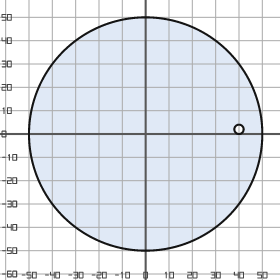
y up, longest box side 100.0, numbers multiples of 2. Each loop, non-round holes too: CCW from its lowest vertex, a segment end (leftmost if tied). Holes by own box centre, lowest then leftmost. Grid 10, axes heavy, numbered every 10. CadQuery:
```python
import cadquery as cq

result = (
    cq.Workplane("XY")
    .moveTo(0.0, 0.0)
    .circle(50.0)
    .moveTo(40.0, 2.0)
    .circle(2.0)
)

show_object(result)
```